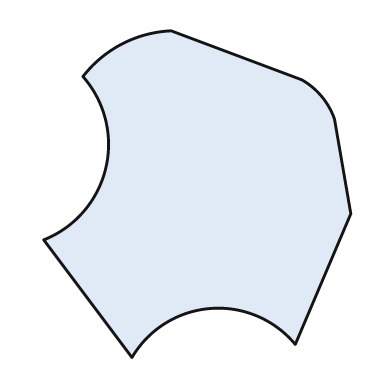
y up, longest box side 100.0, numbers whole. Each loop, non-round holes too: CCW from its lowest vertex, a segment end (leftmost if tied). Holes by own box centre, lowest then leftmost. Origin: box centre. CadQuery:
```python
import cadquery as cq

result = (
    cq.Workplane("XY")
    .moveTo(-20.0, -50.0)
    .threePointArc((4.0, -35.0), (30.0, -46.0))
    .lineTo(47.0, -6.0)
    .lineTo(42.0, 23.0)
    .threePointArc((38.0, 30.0), (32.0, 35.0))
    .lineTo(-8.0, 50.0)
    .threePointArc((-23.0, 46.0), (-35.0, 36.0))
    .threePointArc((-28.0, 8.0), (-47.0, -14.0))
    .close()
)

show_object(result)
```